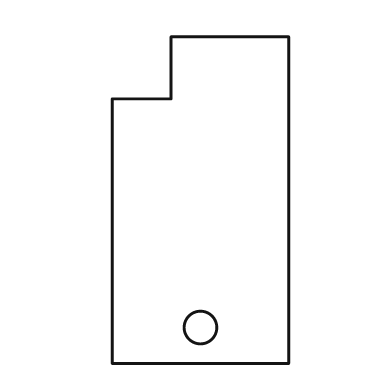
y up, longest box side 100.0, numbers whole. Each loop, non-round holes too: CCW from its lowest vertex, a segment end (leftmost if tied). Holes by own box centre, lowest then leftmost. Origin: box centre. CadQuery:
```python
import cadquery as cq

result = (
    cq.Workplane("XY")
    .moveTo(-27.0, -50.0)
    .lineTo(27.0, -50.0)
    .lineTo(27.0, 50.0)
    .lineTo(-9.0, 50.0)
    .lineTo(-9.0, 31.0)
    .lineTo(-27.0, 31.0)
    .close()
    .moveTo(0.0, -39.0)
    .circle(5.0)
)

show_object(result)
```